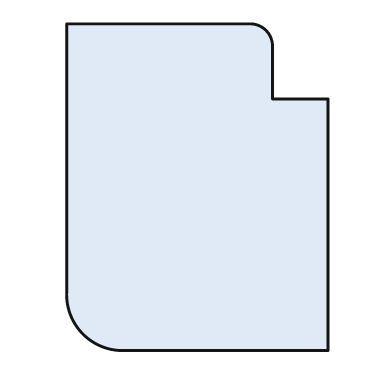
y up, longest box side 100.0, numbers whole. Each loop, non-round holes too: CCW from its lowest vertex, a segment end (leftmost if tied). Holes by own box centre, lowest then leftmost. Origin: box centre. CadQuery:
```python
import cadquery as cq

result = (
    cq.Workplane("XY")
    .moveTo(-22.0, -50.0)
    .lineTo(40.0, -50.0)
    .lineTo(40.0, 27.0)
    .lineTo(23.0, 27.0)
    .lineTo(23.0, 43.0)
    .threePointArc((21.0, 48.0), (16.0, 50.0))
    .lineTo(-40.0, 50.0)
    .lineTo(-40.0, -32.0)
    .threePointArc((-35.0, -45.0), (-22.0, -50.0))
    .close()
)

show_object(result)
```